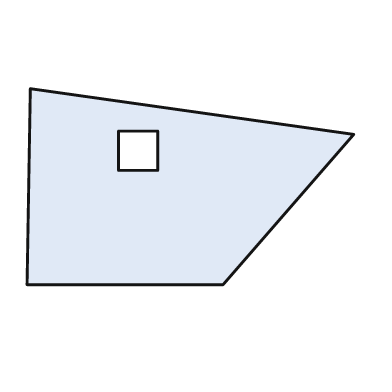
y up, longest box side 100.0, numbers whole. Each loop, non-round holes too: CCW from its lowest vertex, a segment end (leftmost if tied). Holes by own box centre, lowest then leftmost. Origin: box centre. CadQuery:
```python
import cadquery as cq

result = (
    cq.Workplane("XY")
    .moveTo(-50.0, -30.0)
    .lineTo(10.0, -30.0)
    .lineTo(50.0, 16.0)
    .lineTo(-49.0, 30.0)
    .close()
    .moveTo(-22.0, 5.0)
    .lineTo(-10.0, 5.0)
    .lineTo(-10.0, 17.0)
    .lineTo(-22.0, 17.0)
    .close()
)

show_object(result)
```